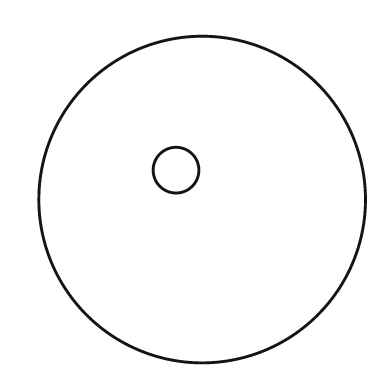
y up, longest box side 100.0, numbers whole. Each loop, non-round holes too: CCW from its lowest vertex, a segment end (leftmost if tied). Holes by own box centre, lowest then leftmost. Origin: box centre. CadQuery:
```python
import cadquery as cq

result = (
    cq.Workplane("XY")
    .moveTo(0.0, 0.0)
    .circle(50.0)
    .moveTo(-8.0, 9.0)
    .circle(7.0)
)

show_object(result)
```